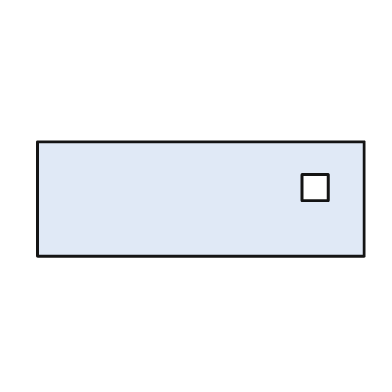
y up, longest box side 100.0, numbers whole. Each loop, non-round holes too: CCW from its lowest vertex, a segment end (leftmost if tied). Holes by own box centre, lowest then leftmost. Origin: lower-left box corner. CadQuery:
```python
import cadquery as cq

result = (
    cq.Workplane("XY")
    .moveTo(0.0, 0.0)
    .lineTo(100.0, 0.0)
    .lineTo(100.0, 35.0)
    .lineTo(0.0, 35.0)
    .close()
    .moveTo(81.0, 17.0)
    .lineTo(89.0, 17.0)
    .lineTo(89.0, 25.0)
    .lineTo(81.0, 25.0)
    .close()
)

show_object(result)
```